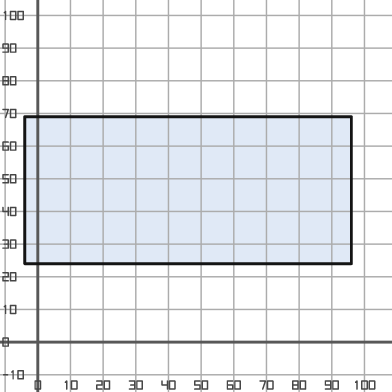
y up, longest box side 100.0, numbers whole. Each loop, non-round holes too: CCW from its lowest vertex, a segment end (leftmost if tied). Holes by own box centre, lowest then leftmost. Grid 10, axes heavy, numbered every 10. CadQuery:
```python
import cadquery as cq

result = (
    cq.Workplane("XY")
    .moveTo(-4.0, 24.0)
    .lineTo(96.0, 24.0)
    .lineTo(96.0, 69.0)
    .lineTo(-4.0, 69.0)
    .close()
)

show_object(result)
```